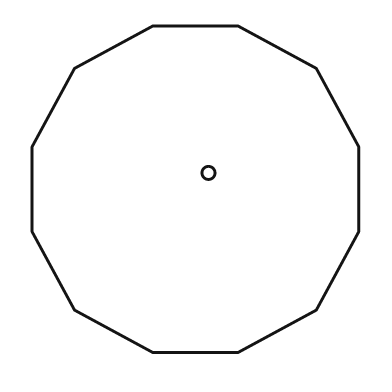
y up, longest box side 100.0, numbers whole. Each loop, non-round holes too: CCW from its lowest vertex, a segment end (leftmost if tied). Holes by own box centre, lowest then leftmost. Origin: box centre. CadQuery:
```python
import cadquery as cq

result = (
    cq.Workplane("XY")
    .moveTo(-13.0, -50.0)
    .lineTo(13.0, -50.0)
    .lineTo(37.0, -37.0)
    .lineTo(50.0, -13.0)
    .lineTo(50.0, 13.0)
    .lineTo(37.0, 37.0)
    .lineTo(13.0, 50.0)
    .lineTo(-13.0, 50.0)
    .lineTo(-37.0, 37.0)
    .lineTo(-50.0, 13.0)
    .lineTo(-50.0, -13.0)
    .lineTo(-37.0, -37.0)
    .close()
    .moveTo(4.0, 5.0)
    .circle(2.0)
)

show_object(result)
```